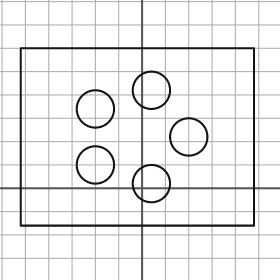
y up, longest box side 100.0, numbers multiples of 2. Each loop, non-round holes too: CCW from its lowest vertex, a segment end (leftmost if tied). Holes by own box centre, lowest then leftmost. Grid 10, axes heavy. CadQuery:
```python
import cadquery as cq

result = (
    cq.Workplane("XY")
    .moveTo(-52.0, -16.0)
    .lineTo(48.0, -16.0)
    .lineTo(48.0, 60.0)
    .lineTo(-52.0, 60.0)
    .close()
    .moveTo(4.0, 2.0)
    .circle(8.0)
    .moveTo(-20.0, 10.0)
    .circle(8.0)
    .moveTo(20.0, 22.0)
    .circle(8.0)
    .moveTo(-20.0, 34.0)
    .circle(8.0)
    .moveTo(4.0, 42.0)
    .circle(8.0)
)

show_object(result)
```